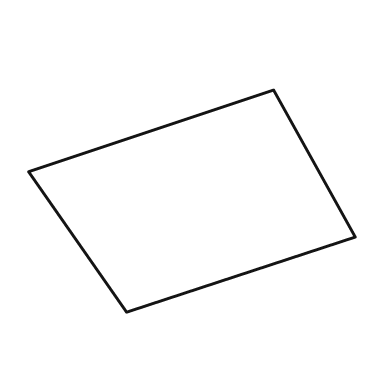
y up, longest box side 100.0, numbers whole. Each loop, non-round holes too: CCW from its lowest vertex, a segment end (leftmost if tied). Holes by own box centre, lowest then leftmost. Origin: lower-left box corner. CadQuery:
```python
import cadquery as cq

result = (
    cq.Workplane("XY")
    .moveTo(30.0, 0.0)
    .lineTo(100.0, 23.0)
    .lineTo(75.0, 68.0)
    .lineTo(0.0, 43.0)
    .close()
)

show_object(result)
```